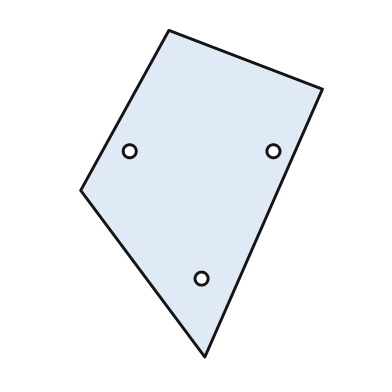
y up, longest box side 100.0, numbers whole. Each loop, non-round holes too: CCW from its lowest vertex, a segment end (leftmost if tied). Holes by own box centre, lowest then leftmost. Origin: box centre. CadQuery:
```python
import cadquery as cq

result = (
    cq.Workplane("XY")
    .moveTo(1.0, -50.0)
    .lineTo(37.0, 32.0)
    .lineTo(-10.0, 50.0)
    .lineTo(-37.0, 1.0)
    .close()
    .moveTo(0.0, -26.0)
    .circle(2.0)
    .moveTo(-22.0, 13.0)
    .circle(2.0)
    .moveTo(22.0, 13.0)
    .circle(2.0)
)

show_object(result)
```